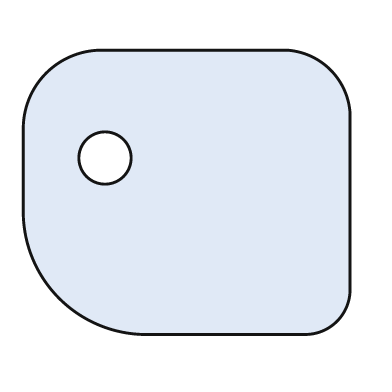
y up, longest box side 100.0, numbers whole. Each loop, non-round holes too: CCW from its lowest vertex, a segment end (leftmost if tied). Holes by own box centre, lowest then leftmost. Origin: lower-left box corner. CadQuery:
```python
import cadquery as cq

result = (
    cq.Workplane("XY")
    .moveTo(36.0, 0.0)
    .lineTo(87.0, 0.0)
    .threePointArc((96.0, 4.0), (100.0, 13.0))
    .lineTo(100.0, 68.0)
    .threePointArc((94.0, 81.0), (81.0, 87.0))
    .lineTo(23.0, 87.0)
    .threePointArc((7.0, 80.0), (0.0, 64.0))
    .lineTo(0.0, 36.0)
    .threePointArc((11.0, 11.0), (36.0, 0.0))
    .close()
    .moveTo(25.0, 54.0)
    .circle(8.0)
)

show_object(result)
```